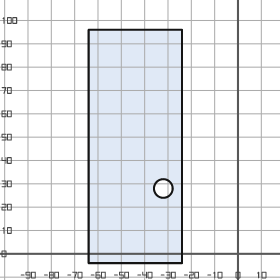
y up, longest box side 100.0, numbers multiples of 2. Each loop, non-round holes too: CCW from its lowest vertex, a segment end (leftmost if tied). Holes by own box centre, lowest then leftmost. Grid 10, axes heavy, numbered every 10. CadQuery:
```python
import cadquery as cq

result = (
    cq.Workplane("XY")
    .moveTo(-64.0, -4.0)
    .lineTo(-24.0, -4.0)
    .lineTo(-24.0, 96.0)
    .lineTo(-64.0, 96.0)
    .close()
    .moveTo(-32.0, 28.0)
    .circle(4.0)
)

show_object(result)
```